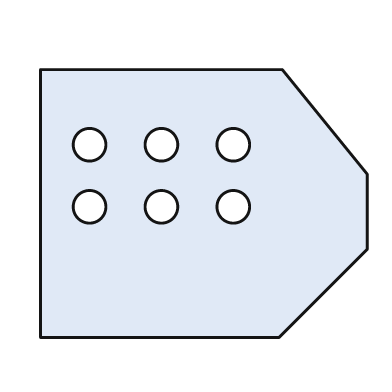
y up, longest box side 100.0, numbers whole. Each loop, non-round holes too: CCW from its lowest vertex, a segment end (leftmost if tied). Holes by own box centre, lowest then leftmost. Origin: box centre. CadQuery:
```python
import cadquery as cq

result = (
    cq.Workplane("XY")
    .moveTo(-50.0, -41.0)
    .lineTo(23.0, -41.0)
    .lineTo(50.0, -14.0)
    .lineTo(50.0, 9.0)
    .lineTo(24.0, 41.0)
    .lineTo(-50.0, 41.0)
    .close()
    .moveTo(-35.0, -1.0)
    .circle(5.0)
    .moveTo(-13.0, -1.0)
    .circle(5.0)
    .moveTo(9.0, -1.0)
    .circle(5.0)
    .moveTo(-35.0, 18.0)
    .circle(5.0)
    .moveTo(-13.0, 18.0)
    .circle(5.0)
    .moveTo(9.0, 18.0)
    .circle(5.0)
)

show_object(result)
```